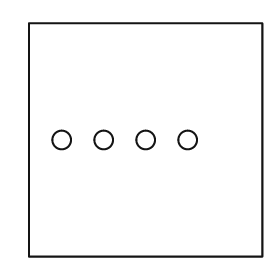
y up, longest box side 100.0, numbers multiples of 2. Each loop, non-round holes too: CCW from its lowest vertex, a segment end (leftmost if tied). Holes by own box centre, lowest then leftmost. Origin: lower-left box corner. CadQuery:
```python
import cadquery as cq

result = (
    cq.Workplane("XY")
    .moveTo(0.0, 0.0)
    .lineTo(100.0, 0.0)
    .lineTo(100.0, 100.0)
    .lineTo(0.0, 100.0)
    .close()
    .moveTo(14.0, 50.0)
    .circle(4.0)
    .moveTo(32.0, 50.0)
    .circle(4.0)
    .moveTo(50.0, 50.0)
    .circle(4.0)
    .moveTo(68.0, 50.0)
    .circle(4.0)
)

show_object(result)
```